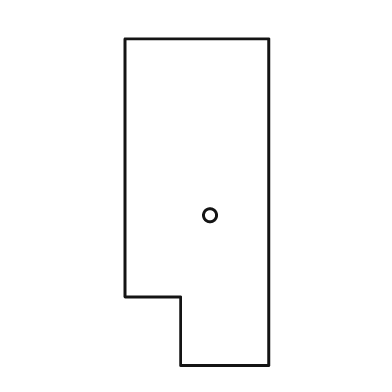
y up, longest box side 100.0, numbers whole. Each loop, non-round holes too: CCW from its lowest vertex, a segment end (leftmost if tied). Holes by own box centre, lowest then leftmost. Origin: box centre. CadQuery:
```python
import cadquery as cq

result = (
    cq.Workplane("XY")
    .moveTo(-5.0, -50.0)
    .lineTo(22.0, -50.0)
    .lineTo(22.0, 50.0)
    .lineTo(-22.0, 50.0)
    .lineTo(-22.0, -29.0)
    .lineTo(-5.0, -29.0)
    .close()
    .moveTo(4.0, -4.0)
    .circle(2.0)
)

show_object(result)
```